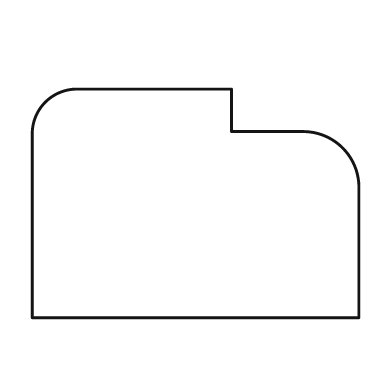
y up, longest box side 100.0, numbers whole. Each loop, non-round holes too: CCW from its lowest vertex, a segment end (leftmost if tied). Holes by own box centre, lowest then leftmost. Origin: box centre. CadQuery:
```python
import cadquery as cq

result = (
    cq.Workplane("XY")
    .moveTo(-50.0, -35.0)
    .lineTo(50.0, -35.0)
    .lineTo(50.0, 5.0)
    .threePointArc((45.0, 17.0), (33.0, 22.0))
    .lineTo(11.0, 22.0)
    .lineTo(11.0, 35.0)
    .lineTo(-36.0, 35.0)
    .threePointArc((-46.0, 31.0), (-50.0, 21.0))
    .close()
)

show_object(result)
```